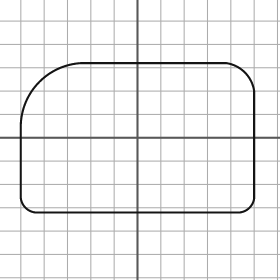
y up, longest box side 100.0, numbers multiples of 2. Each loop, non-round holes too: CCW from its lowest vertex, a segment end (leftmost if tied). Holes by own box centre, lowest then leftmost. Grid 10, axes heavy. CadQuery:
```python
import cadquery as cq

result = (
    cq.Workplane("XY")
    .moveTo(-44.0, -32.0)
    .lineTo(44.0, -32.0)
    .threePointArc((48.0, -30.0), (50.0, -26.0))
    .lineTo(50.0, 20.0)
    .threePointArc((46.0, 28.0), (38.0, 32.0))
    .lineTo(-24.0, 32.0)
    .threePointArc((-42.0, 24.0), (-50.0, 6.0))
    .lineTo(-50.0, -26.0)
    .threePointArc((-48.0, -30.0), (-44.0, -32.0))
    .close()
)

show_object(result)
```